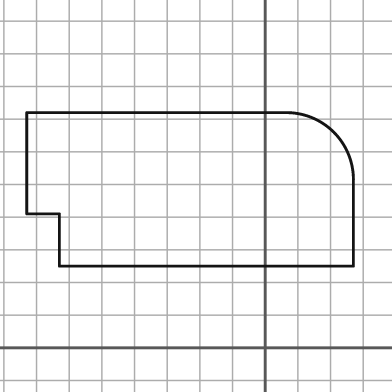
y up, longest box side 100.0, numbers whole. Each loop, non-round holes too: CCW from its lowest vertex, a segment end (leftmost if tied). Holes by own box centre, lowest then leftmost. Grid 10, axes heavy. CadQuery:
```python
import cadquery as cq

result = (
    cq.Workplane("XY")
    .moveTo(-63.0, 25.0)
    .lineTo(27.0, 25.0)
    .lineTo(27.0, 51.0)
    .threePointArc((21.0, 66.0), (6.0, 72.0))
    .lineTo(-73.0, 72.0)
    .lineTo(-73.0, 41.0)
    .lineTo(-63.0, 41.0)
    .close()
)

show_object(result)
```